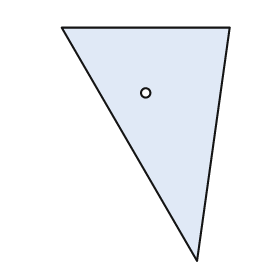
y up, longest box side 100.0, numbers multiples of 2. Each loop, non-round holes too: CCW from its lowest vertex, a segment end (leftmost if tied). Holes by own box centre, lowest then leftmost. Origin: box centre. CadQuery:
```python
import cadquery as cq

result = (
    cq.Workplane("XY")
    .moveTo(22.0, -50.0)
    .lineTo(36.0, 50.0)
    .lineTo(-36.0, 50.0)
    .close()
    .moveTo(0.0, 22.0)
    .circle(2.0)
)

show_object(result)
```